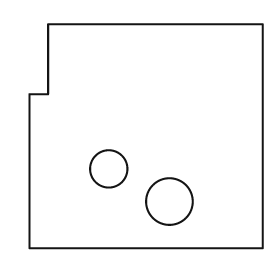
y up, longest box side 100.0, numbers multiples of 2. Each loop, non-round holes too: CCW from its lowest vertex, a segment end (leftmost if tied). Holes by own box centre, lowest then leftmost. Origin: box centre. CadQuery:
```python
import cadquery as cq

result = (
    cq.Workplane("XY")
    .moveTo(-50.0, -48.0)
    .lineTo(50.0, -48.0)
    .lineTo(50.0, 48.0)
    .lineTo(-42.0, 48.0)
    .lineTo(-42.0, 18.0)
    .lineTo(-50.0, 18.0)
    .close()
    .moveTo(10.0, -28.0)
    .circle(10.0)
    .moveTo(-16.0, -14.0)
    .circle(8.0)
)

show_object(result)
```